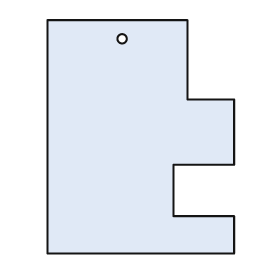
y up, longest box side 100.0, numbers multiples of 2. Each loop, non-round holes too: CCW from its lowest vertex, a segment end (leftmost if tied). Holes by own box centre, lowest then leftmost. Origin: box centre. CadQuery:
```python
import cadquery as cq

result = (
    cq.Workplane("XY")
    .moveTo(-40.0, -50.0)
    .lineTo(40.0, -50.0)
    .lineTo(40.0, -34.0)
    .lineTo(14.0, -34.0)
    .lineTo(14.0, -12.0)
    .lineTo(40.0, -12.0)
    .lineTo(40.0, 16.0)
    .lineTo(20.0, 16.0)
    .lineTo(20.0, 50.0)
    .lineTo(-40.0, 50.0)
    .close()
    .moveTo(-8.0, 42.0)
    .circle(2.0)
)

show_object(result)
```